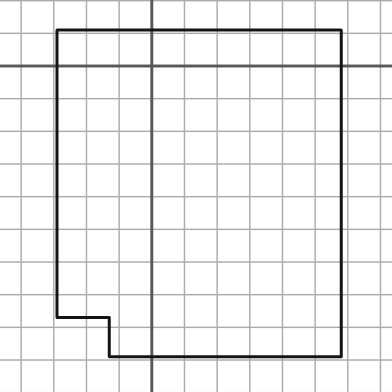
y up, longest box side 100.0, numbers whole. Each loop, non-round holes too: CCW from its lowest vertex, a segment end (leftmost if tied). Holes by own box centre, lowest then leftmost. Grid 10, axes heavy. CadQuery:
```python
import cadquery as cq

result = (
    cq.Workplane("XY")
    .moveTo(-13.0, -89.0)
    .lineTo(58.0, -89.0)
    .lineTo(58.0, 11.0)
    .lineTo(-29.0, 11.0)
    .lineTo(-29.0, -77.0)
    .lineTo(-13.0, -77.0)
    .close()
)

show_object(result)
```